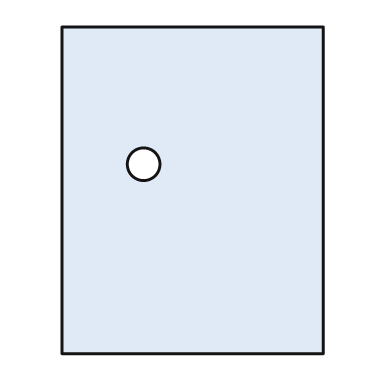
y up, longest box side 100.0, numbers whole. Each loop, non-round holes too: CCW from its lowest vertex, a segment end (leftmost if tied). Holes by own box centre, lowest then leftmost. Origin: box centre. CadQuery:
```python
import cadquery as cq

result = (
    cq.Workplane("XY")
    .moveTo(-40.0, -50.0)
    .lineTo(40.0, -50.0)
    .lineTo(40.0, 50.0)
    .lineTo(-40.0, 50.0)
    .close()
    .moveTo(-15.0, 8.0)
    .circle(5.0)
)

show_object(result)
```